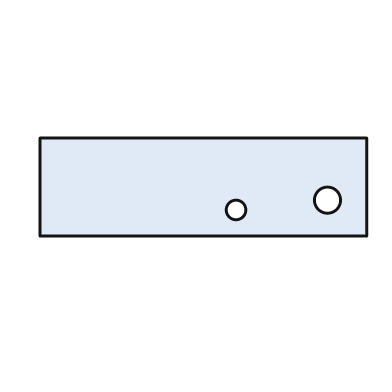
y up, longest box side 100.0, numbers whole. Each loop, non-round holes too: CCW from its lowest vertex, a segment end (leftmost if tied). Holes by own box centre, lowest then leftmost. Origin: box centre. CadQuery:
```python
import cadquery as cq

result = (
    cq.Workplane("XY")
    .moveTo(-50.0, -15.0)
    .lineTo(50.0, -15.0)
    .lineTo(50.0, 15.0)
    .lineTo(-50.0, 15.0)
    .close()
    .moveTo(10.0, -7.0)
    .circle(3.0)
    .moveTo(38.0, -4.0)
    .circle(4.0)
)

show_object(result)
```